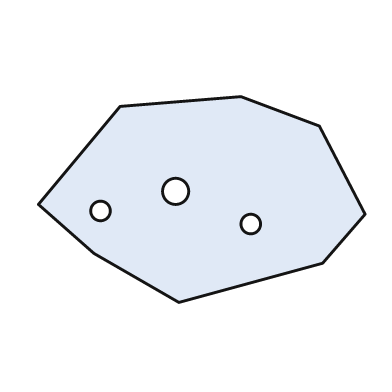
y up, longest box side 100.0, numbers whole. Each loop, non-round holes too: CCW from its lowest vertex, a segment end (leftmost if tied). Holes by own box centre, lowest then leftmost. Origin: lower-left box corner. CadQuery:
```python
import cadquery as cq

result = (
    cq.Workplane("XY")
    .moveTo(43.0, 0.0)
    .lineTo(87.0, 12.0)
    .lineTo(100.0, 27.0)
    .lineTo(86.0, 54.0)
    .lineTo(62.0, 63.0)
    .lineTo(25.0, 60.0)
    .lineTo(0.0, 30.0)
    .lineTo(17.0, 15.0)
    .close()
    .moveTo(65.0, 24.0)
    .circle(3.0)
    .moveTo(19.0, 28.0)
    .circle(3.0)
    .moveTo(42.0, 34.0)
    .circle(4.0)
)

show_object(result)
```